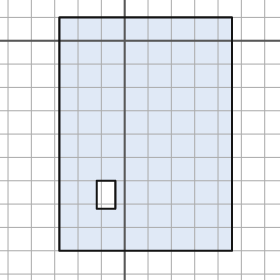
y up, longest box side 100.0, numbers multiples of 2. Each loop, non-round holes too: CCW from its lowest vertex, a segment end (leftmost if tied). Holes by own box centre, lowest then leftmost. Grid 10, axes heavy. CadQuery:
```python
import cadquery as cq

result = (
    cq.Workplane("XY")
    .moveTo(-28.0, -90.0)
    .lineTo(46.0, -90.0)
    .lineTo(46.0, 10.0)
    .lineTo(-28.0, 10.0)
    .close()
    .moveTo(-12.0, -72.0)
    .lineTo(-4.0, -72.0)
    .lineTo(-4.0, -60.0)
    .lineTo(-12.0, -60.0)
    .close()
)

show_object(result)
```